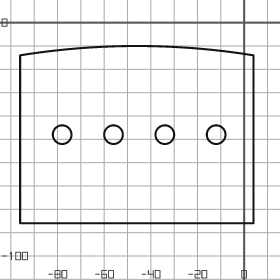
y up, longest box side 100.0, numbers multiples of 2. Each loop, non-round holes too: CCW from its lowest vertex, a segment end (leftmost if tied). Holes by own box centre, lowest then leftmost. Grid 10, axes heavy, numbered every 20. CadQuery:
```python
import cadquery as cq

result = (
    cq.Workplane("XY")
    .moveTo(-96.0, -86.0)
    .lineTo(4.0, -86.0)
    .lineTo(4.0, -14.0)
    .threePointArc((-46.0, -10.0), (-96.0, -14.0))
    .close()
    .moveTo(-78.0, -48.0)
    .circle(4.0)
    .moveTo(-56.0, -48.0)
    .circle(4.0)
    .moveTo(-34.0, -48.0)
    .circle(4.0)
    .moveTo(-12.0, -48.0)
    .circle(4.0)
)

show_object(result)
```